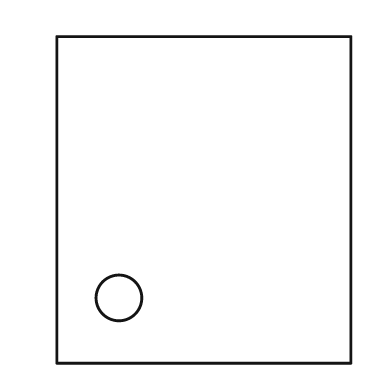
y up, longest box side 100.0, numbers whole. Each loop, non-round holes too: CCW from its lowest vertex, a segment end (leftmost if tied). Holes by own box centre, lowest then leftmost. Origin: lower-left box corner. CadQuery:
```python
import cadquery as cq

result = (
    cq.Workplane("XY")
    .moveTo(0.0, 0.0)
    .lineTo(90.0, 0.0)
    .lineTo(90.0, 100.0)
    .lineTo(0.0, 100.0)
    .close()
    .moveTo(19.0, 20.0)
    .circle(7.0)
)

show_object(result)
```